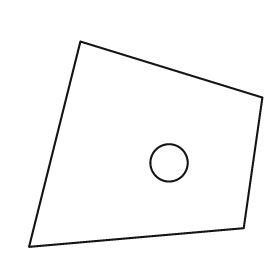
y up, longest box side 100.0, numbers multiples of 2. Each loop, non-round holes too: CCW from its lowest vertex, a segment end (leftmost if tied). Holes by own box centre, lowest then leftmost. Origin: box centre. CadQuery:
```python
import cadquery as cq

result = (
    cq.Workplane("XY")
    .moveTo(-50.0, -44.0)
    .lineTo(42.0, -36.0)
    .lineTo(50.0, 20.0)
    .lineTo(-28.0, 44.0)
    .close()
    .moveTo(10.0, -8.0)
    .circle(8.0)
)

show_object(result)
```